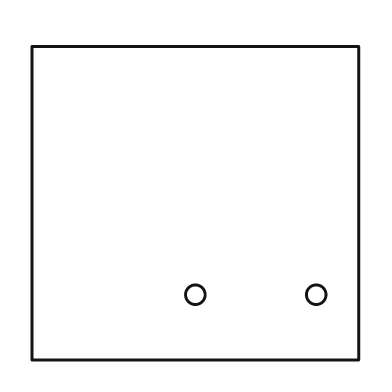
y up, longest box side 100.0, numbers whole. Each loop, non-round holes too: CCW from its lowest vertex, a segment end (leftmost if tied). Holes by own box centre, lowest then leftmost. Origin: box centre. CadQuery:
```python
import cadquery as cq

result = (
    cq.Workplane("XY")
    .moveTo(-50.0, -48.0)
    .lineTo(50.0, -48.0)
    .lineTo(50.0, 48.0)
    .lineTo(-50.0, 48.0)
    .close()
    .moveTo(0.0, -28.0)
    .circle(3.0)
    .moveTo(37.0, -28.0)
    .circle(3.0)
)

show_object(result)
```